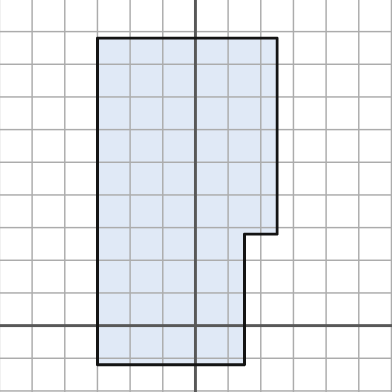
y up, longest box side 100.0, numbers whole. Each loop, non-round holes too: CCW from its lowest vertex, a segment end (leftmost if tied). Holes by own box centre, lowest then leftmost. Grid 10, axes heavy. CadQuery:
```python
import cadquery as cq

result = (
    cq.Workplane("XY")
    .moveTo(-30.0, -12.0)
    .lineTo(15.0, -12.0)
    .lineTo(15.0, 28.0)
    .lineTo(25.0, 28.0)
    .lineTo(25.0, 88.0)
    .lineTo(-30.0, 88.0)
    .close()
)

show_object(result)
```